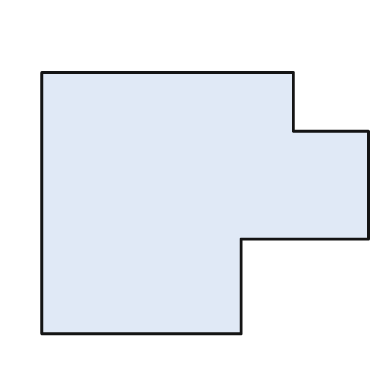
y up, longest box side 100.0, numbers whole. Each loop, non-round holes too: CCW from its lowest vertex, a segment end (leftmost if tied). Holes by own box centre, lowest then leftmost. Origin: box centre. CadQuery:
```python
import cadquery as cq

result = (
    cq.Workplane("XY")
    .moveTo(-50.0, -40.0)
    .lineTo(11.0, -40.0)
    .lineTo(11.0, -11.0)
    .lineTo(50.0, -11.0)
    .lineTo(50.0, 22.0)
    .lineTo(27.0, 22.0)
    .lineTo(27.0, 40.0)
    .lineTo(-50.0, 40.0)
    .close()
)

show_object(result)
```